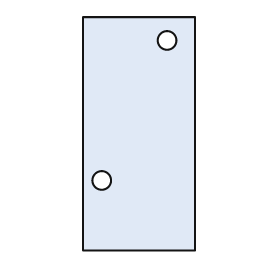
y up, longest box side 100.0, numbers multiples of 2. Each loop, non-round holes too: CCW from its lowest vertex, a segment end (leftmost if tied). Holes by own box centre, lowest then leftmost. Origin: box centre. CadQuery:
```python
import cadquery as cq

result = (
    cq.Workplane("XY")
    .moveTo(-24.0, -50.0)
    .lineTo(24.0, -50.0)
    .lineTo(24.0, 50.0)
    .lineTo(-24.0, 50.0)
    .close()
    .moveTo(-16.0, -20.0)
    .circle(4.0)
    .moveTo(12.0, 40.0)
    .circle(4.0)
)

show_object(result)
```